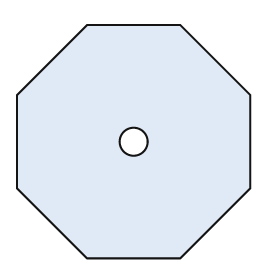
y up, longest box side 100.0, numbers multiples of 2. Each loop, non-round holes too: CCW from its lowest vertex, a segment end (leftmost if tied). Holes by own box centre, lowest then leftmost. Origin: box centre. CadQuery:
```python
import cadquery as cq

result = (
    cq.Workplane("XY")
    .moveTo(-20.0, -50.0)
    .lineTo(20.0, -50.0)
    .lineTo(50.0, -20.0)
    .lineTo(50.0, 20.0)
    .lineTo(20.0, 50.0)
    .lineTo(-20.0, 50.0)
    .lineTo(-50.0, 20.0)
    .lineTo(-50.0, -20.0)
    .close()
    .moveTo(0.0, 0.0)
    .circle(6.0)
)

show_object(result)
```